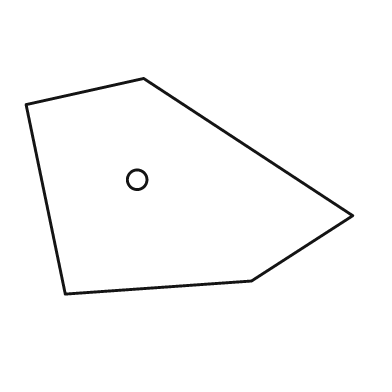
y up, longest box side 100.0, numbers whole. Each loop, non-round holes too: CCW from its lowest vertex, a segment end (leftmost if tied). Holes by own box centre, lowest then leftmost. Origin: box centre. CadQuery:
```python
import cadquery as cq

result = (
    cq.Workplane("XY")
    .moveTo(-38.0, -33.0)
    .lineTo(19.0, -29.0)
    .lineTo(50.0, -9.0)
    .lineTo(-14.0, 33.0)
    .lineTo(-50.0, 25.0)
    .close()
    .moveTo(-16.0, 2.0)
    .circle(3.0)
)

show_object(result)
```